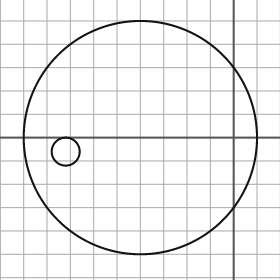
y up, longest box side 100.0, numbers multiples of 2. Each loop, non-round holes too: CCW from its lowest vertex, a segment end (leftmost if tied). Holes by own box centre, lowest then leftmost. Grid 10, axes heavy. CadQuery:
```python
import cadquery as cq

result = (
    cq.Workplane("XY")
    .moveTo(-40.0, 0.0)
    .circle(50.0)
    .moveTo(-72.0, -6.0)
    .circle(6.0)
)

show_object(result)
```